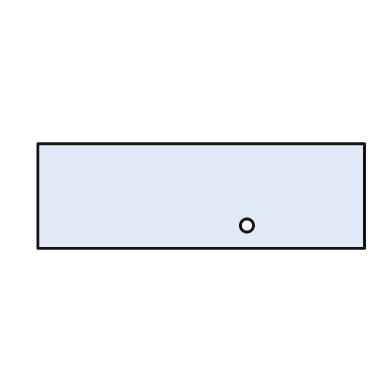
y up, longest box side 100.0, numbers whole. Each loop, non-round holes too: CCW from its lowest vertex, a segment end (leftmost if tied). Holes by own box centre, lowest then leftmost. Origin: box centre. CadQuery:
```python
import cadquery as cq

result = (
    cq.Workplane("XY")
    .moveTo(-50.0, -16.0)
    .lineTo(50.0, -16.0)
    .lineTo(50.0, 16.0)
    .lineTo(-50.0, 16.0)
    .close()
    .moveTo(14.0, -9.0)
    .circle(2.0)
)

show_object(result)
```